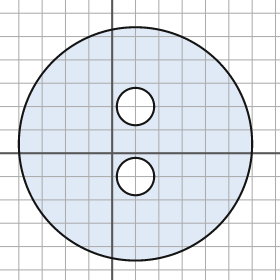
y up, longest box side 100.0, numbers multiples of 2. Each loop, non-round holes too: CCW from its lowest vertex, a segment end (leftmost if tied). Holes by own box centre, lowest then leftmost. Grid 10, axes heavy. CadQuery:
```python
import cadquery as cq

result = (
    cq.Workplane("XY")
    .moveTo(10.0, 4.0)
    .circle(50.0)
    .moveTo(10.0, -10.0)
    .circle(8.0)
    .moveTo(10.0, 20.0)
    .circle(8.0)
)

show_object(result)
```